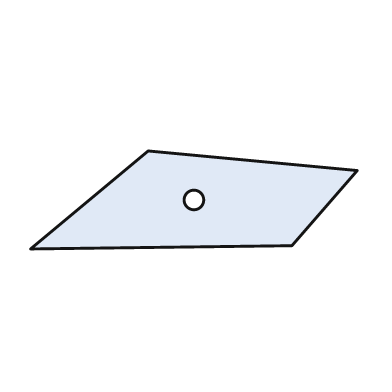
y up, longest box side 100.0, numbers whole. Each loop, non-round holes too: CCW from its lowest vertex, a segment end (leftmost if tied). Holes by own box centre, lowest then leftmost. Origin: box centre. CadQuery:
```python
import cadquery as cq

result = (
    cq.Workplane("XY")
    .moveTo(-50.0, -15.0)
    .lineTo(30.0, -14.0)
    .lineTo(50.0, 9.0)
    .lineTo(-14.0, 15.0)
    .close()
    .moveTo(0.0, 0.0)
    .circle(3.0)
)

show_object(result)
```